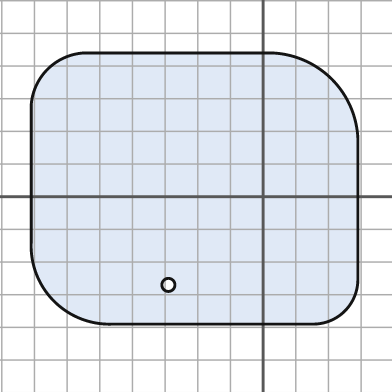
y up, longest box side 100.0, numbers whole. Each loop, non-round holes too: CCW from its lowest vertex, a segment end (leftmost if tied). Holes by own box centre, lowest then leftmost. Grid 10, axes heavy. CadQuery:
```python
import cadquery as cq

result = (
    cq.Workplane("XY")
    .moveTo(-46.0, -39.0)
    .lineTo(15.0, -39.0)
    .threePointArc((25.0, -35.0), (29.0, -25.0))
    .lineTo(29.0, 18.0)
    .threePointArc((21.0, 36.0), (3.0, 44.0))
    .lineTo(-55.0, 44.0)
    .threePointArc((-66.0, 39.0), (-71.0, 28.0))
    .lineTo(-71.0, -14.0)
    .threePointArc((-64.0, -32.0), (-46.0, -39.0))
    .close()
    .moveTo(-29.0, -27.0)
    .circle(2.0)
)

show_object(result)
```